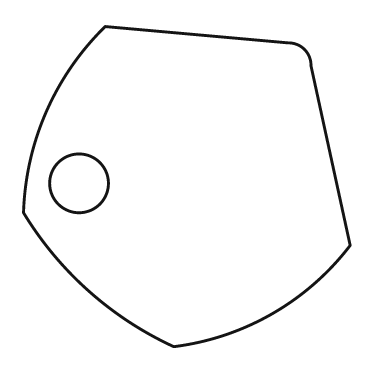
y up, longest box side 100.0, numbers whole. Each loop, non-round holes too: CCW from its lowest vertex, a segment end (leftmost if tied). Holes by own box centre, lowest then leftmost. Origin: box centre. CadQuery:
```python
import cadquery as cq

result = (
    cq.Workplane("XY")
    .moveTo(-4.0, -49.0)
    .threePointArc((26.0, -39.0), (50.0, -18.0))
    .lineTo(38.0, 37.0)
    .threePointArc((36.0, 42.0), (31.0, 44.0))
    .lineTo(-25.0, 49.0)
    .threePointArc((-43.0, 23.0), (-50.0, -8.0))
    .threePointArc((-30.0, -32.0), (-4.0, -49.0))
    .close()
    .moveTo(-33.0, 1.0)
    .circle(9.0)
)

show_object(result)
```